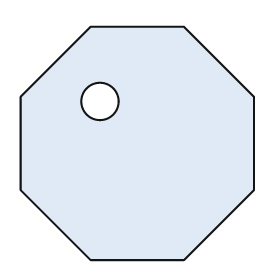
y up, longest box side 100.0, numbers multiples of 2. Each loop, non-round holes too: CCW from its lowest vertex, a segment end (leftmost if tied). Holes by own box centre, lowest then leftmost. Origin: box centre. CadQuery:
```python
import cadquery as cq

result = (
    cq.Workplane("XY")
    .moveTo(-20.0, -50.0)
    .lineTo(20.0, -50.0)
    .lineTo(50.0, -20.0)
    .lineTo(50.0, 20.0)
    .lineTo(20.0, 50.0)
    .lineTo(-20.0, 50.0)
    .lineTo(-50.0, 20.0)
    .lineTo(-50.0, -20.0)
    .close()
    .moveTo(-16.0, 18.0)
    .circle(8.0)
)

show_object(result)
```